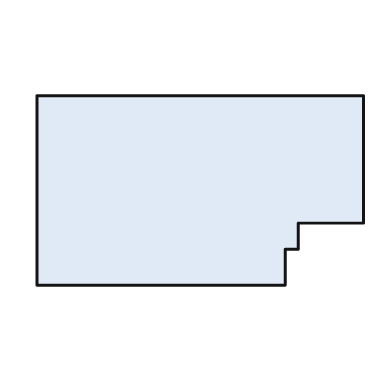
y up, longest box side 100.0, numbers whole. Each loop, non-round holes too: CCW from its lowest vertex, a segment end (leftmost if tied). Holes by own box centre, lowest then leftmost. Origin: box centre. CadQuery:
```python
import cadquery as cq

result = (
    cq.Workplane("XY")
    .moveTo(-50.0, -29.0)
    .lineTo(26.0, -29.0)
    .lineTo(26.0, -18.0)
    .lineTo(30.0, -18.0)
    .lineTo(30.0, -10.0)
    .lineTo(50.0, -10.0)
    .lineTo(50.0, 29.0)
    .lineTo(-50.0, 29.0)
    .close()
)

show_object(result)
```